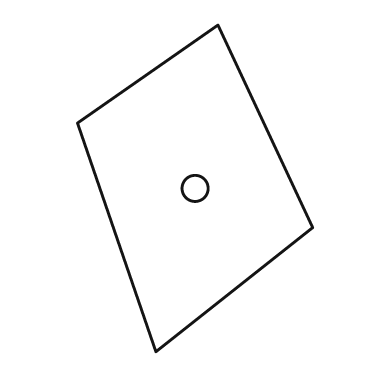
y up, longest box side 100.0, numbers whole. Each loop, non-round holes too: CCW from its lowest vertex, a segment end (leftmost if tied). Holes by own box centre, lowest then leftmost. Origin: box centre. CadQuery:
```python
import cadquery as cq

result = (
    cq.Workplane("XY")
    .moveTo(-12.0, -50.0)
    .lineTo(36.0, -12.0)
    .lineTo(7.0, 50.0)
    .lineTo(-36.0, 20.0)
    .close()
    .moveTo(0.0, 0.0)
    .circle(4.0)
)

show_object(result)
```